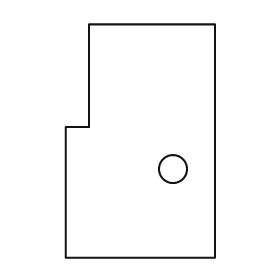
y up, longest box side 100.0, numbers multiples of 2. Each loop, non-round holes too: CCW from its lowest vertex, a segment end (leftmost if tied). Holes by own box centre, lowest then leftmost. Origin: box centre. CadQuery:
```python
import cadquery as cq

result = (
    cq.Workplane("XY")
    .moveTo(-32.0, -50.0)
    .lineTo(32.0, -50.0)
    .lineTo(32.0, 50.0)
    .lineTo(-22.0, 50.0)
    .lineTo(-22.0, 6.0)
    .lineTo(-32.0, 6.0)
    .close()
    .moveTo(14.0, -12.0)
    .circle(6.0)
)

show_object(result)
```